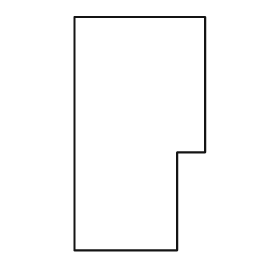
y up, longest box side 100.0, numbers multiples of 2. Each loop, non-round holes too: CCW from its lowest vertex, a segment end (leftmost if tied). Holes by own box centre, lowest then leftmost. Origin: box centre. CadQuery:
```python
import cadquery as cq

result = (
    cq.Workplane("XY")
    .moveTo(-28.0, -50.0)
    .lineTo(16.0, -50.0)
    .lineTo(16.0, -8.0)
    .lineTo(28.0, -8.0)
    .lineTo(28.0, 50.0)
    .lineTo(-28.0, 50.0)
    .close()
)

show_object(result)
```